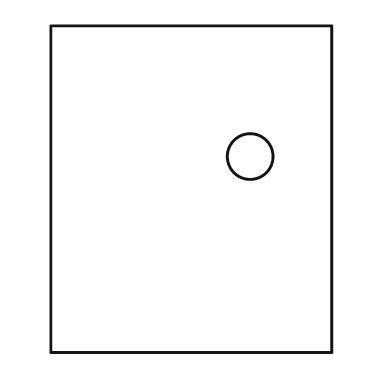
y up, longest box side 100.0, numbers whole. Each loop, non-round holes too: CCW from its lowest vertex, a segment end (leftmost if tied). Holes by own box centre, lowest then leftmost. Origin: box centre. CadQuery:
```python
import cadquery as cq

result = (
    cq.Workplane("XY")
    .moveTo(-43.0, -50.0)
    .lineTo(43.0, -50.0)
    .lineTo(43.0, 50.0)
    .lineTo(-43.0, 50.0)
    .close()
    .moveTo(18.0, 10.0)
    .circle(7.0)
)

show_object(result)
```